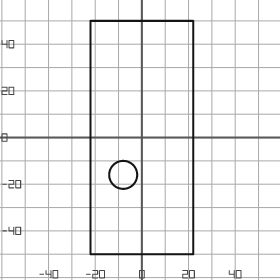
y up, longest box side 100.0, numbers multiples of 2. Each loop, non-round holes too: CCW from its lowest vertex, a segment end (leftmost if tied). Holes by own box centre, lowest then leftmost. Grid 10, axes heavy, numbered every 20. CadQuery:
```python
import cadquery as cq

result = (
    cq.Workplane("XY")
    .moveTo(-22.0, -50.0)
    .lineTo(22.0, -50.0)
    .lineTo(22.0, 50.0)
    .lineTo(-22.0, 50.0)
    .close()
    .moveTo(-8.0, -16.0)
    .circle(6.0)
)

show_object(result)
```